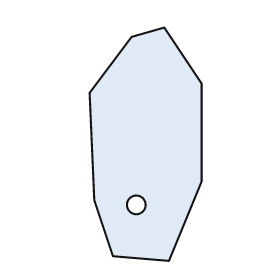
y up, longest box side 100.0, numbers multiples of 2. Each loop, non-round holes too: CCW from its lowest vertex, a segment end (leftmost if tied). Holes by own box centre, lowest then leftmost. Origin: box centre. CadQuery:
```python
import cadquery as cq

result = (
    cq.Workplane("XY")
    .moveTo(10.0, -50.0)
    .lineTo(24.0, -16.0)
    .lineTo(24.0, 26.0)
    .lineTo(8.0, 50.0)
    .lineTo(-6.0, 46.0)
    .lineTo(-24.0, 22.0)
    .lineTo(-22.0, -24.0)
    .lineTo(-14.0, -48.0)
    .close()
    .moveTo(-4.0, -26.0)
    .circle(4.0)
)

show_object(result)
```